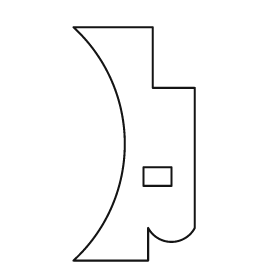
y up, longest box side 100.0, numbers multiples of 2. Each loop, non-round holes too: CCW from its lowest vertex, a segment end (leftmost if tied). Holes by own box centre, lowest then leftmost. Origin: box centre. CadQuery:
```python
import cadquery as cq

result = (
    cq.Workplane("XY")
    .moveTo(-26.0, -50.0)
    .lineTo(6.0, -50.0)
    .lineTo(6.0, -36.0)
    .threePointArc((16.0, -42.0), (26.0, -36.0))
    .lineTo(26.0, 24.0)
    .lineTo(8.0, 24.0)
    .lineTo(8.0, 50.0)
    .lineTo(-26.0, 50.0)
    .threePointArc((-4.0, 0.0), (-26.0, -50.0))
    .close()
    .moveTo(4.0, -18.0)
    .lineTo(16.0, -18.0)
    .lineTo(16.0, -10.0)
    .lineTo(4.0, -10.0)
    .close()
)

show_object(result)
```